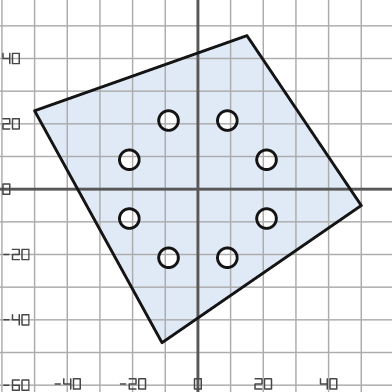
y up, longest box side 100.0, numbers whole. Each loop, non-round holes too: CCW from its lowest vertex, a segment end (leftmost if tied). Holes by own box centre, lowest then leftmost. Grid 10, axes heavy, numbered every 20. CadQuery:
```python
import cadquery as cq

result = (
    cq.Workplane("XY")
    .moveTo(-11.0, -47.0)
    .lineTo(50.0, -5.0)
    .lineTo(15.0, 47.0)
    .lineTo(-50.0, 24.0)
    .close()
    .moveTo(-9.0, -21.0)
    .circle(3.0)
    .moveTo(9.0, -21.0)
    .circle(3.0)
    .moveTo(-21.0, -9.0)
    .circle(3.0)
    .moveTo(21.0, -9.0)
    .circle(3.0)
    .moveTo(-21.0, 9.0)
    .circle(3.0)
    .moveTo(21.0, 9.0)
    .circle(3.0)
    .moveTo(-9.0, 21.0)
    .circle(3.0)
    .moveTo(9.0, 21.0)
    .circle(3.0)
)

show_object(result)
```